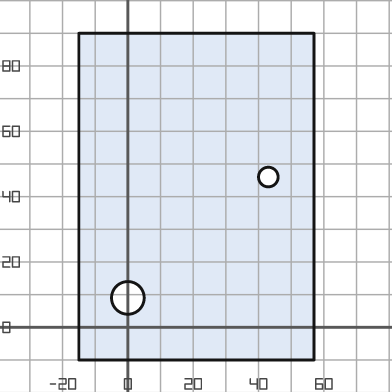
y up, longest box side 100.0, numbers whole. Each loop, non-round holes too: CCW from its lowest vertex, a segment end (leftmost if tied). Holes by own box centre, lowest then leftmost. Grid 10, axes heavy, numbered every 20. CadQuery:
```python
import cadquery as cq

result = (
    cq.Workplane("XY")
    .moveTo(-15.0, -10.0)
    .lineTo(57.0, -10.0)
    .lineTo(57.0, 90.0)
    .lineTo(-15.0, 90.0)
    .close()
    .moveTo(0.0, 9.0)
    .circle(5.0)
    .moveTo(43.0, 46.0)
    .circle(3.0)
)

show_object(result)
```